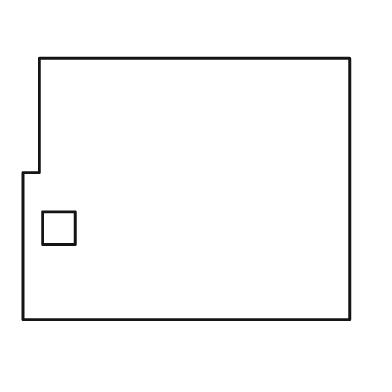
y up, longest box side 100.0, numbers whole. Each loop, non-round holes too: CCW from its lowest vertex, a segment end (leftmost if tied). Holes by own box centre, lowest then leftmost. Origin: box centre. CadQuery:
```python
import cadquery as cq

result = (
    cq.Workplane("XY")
    .moveTo(-50.0, -40.0)
    .lineTo(50.0, -40.0)
    .lineTo(50.0, 40.0)
    .lineTo(-45.0, 40.0)
    .lineTo(-45.0, 5.0)
    .lineTo(-50.0, 5.0)
    .close()
    .moveTo(-44.0, -17.0)
    .lineTo(-34.0, -17.0)
    .lineTo(-34.0, -7.0)
    .lineTo(-44.0, -7.0)
    .close()
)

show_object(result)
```